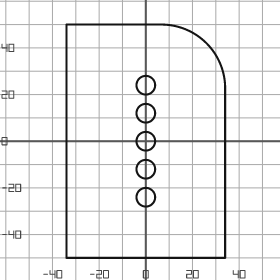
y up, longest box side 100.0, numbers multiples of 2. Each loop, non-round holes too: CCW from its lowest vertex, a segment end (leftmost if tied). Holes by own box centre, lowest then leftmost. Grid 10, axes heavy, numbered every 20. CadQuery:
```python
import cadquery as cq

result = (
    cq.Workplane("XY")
    .moveTo(-34.0, -50.0)
    .lineTo(34.0, -50.0)
    .lineTo(34.0, 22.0)
    .threePointArc((26.0, 42.0), (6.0, 50.0))
    .lineTo(-34.0, 50.0)
    .close()
    .moveTo(0.0, -24.0)
    .circle(4.0)
    .moveTo(0.0, -12.0)
    .circle(4.0)
    .moveTo(0.0, 0.0)
    .circle(4.0)
    .moveTo(0.0, 12.0)
    .circle(4.0)
    .moveTo(0.0, 24.0)
    .circle(4.0)
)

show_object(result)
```